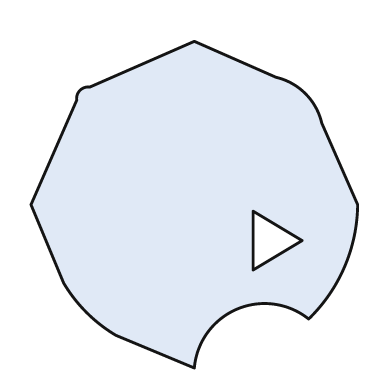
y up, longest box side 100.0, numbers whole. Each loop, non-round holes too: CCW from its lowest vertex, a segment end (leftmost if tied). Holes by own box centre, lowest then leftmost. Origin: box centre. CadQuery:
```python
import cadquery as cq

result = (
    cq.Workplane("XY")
    .moveTo(0.0, -50.0)
    .threePointArc((13.0, -32.0), (35.0, -35.0))
    .threePointArc((46.0, -19.0), (50.0, 0.0))
    .lineTo(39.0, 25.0)
    .threePointArc((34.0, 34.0), (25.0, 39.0))
    .lineTo(0.0, 50.0)
    .lineTo(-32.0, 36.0)
    .threePointArc((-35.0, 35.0), (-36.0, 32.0))
    .lineTo(-50.0, 0.0)
    .lineTo(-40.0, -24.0)
    .threePointArc((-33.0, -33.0), (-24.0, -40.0))
    .close()
    .moveTo(18.0, -20.0)
    .lineTo(33.0, -11.0)
    .lineTo(18.0, -2.0)
    .close()
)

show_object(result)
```